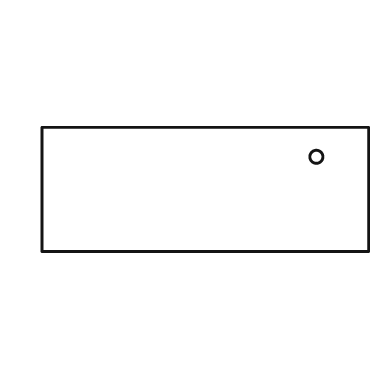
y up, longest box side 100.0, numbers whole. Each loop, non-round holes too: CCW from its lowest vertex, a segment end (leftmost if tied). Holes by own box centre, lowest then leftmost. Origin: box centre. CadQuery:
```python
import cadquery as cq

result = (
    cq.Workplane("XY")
    .moveTo(-50.0, -19.0)
    .lineTo(50.0, -19.0)
    .lineTo(50.0, 19.0)
    .lineTo(-50.0, 19.0)
    .close()
    .moveTo(34.0, 10.0)
    .circle(2.0)
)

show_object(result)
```